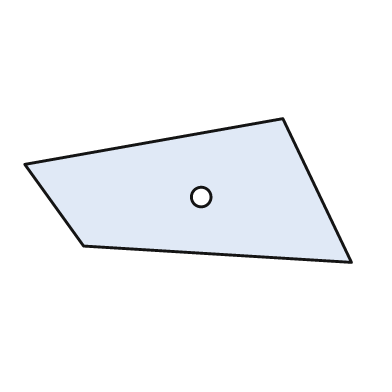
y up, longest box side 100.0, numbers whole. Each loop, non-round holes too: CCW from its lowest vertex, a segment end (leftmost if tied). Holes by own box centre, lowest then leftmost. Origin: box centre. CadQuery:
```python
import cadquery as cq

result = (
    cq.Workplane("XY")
    .moveTo(50.0, -22.0)
    .lineTo(29.0, 22.0)
    .lineTo(-50.0, 8.0)
    .lineTo(-32.0, -17.0)
    .close()
    .moveTo(4.0, -2.0)
    .circle(3.0)
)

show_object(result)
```